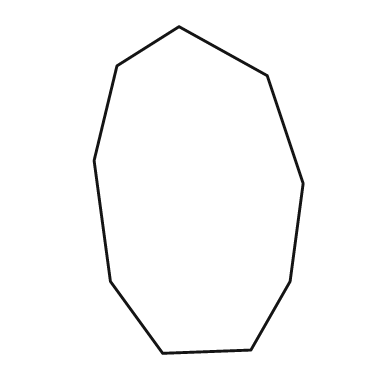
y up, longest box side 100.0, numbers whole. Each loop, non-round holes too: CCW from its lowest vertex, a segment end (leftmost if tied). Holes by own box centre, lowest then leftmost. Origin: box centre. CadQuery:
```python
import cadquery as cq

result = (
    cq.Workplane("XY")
    .moveTo(-11.0, -50.0)
    .lineTo(16.0, -49.0)
    .lineTo(28.0, -28.0)
    .lineTo(32.0, 2.0)
    .lineTo(21.0, 35.0)
    .lineTo(-6.0, 50.0)
    .lineTo(-25.0, 38.0)
    .lineTo(-32.0, 9.0)
    .lineTo(-27.0, -28.0)
    .close()
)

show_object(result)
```